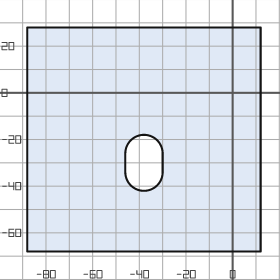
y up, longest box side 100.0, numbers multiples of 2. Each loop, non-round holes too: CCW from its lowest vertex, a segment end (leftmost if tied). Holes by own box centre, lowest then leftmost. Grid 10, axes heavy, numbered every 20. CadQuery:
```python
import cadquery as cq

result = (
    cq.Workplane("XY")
    .moveTo(-88.0, -68.0)
    .lineTo(12.0, -68.0)
    .lineTo(12.0, 28.0)
    .lineTo(-88.0, 28.0)
    .close()
    .moveTo(-46.0, -34.0)
    .threePointArc((-38.0, -42.0), (-30.0, -34.0))
    .lineTo(-30.0, -26.0)
    .threePointArc((-38.0, -18.0), (-46.0, -26.0))
    .close()
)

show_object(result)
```